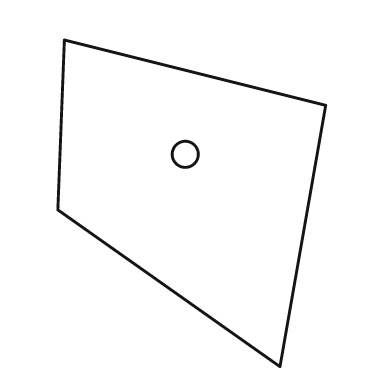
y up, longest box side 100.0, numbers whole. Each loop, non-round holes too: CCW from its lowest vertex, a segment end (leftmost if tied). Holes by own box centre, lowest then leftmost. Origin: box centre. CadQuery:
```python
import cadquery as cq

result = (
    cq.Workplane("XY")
    .moveTo(27.0, -50.0)
    .lineTo(41.0, 30.0)
    .lineTo(-39.0, 50.0)
    .lineTo(-41.0, -2.0)
    .close()
    .moveTo(-2.0, 15.0)
    .circle(4.0)
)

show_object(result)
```